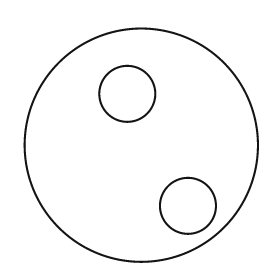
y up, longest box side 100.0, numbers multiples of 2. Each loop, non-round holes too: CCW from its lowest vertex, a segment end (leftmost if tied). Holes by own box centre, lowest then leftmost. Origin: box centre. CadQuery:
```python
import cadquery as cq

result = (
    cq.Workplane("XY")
    .moveTo(0.0, 0.0)
    .circle(50.0)
    .moveTo(20.0, -26.0)
    .circle(12.0)
    .moveTo(-6.0, 22.0)
    .circle(12.0)
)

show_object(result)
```